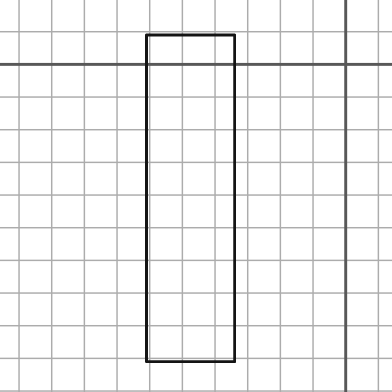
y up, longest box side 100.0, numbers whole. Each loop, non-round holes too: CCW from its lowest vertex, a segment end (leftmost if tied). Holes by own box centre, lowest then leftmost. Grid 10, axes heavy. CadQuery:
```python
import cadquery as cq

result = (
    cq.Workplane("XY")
    .moveTo(-61.0, -91.0)
    .lineTo(-34.0, -91.0)
    .lineTo(-34.0, 9.0)
    .lineTo(-61.0, 9.0)
    .close()
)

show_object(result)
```